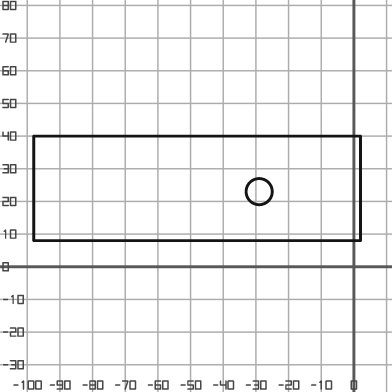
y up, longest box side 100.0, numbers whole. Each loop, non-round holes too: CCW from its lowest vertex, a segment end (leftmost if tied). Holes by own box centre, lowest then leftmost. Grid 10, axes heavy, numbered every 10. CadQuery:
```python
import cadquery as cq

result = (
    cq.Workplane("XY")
    .moveTo(-98.0, 8.0)
    .lineTo(2.0, 8.0)
    .lineTo(2.0, 40.0)
    .lineTo(-98.0, 40.0)
    .close()
    .moveTo(-29.0, 23.0)
    .circle(4.0)
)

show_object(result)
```